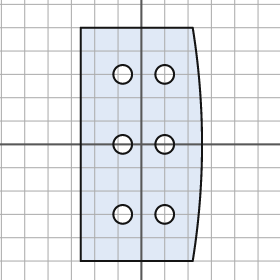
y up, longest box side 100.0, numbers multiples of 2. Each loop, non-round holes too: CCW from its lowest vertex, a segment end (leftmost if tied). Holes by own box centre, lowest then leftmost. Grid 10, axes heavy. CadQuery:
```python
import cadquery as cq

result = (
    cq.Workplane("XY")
    .moveTo(-26.0, -50.0)
    .lineTo(22.0, -50.0)
    .threePointArc((26.0, 0.0), (22.0, 50.0))
    .lineTo(-26.0, 50.0)
    .close()
    .moveTo(-8.0, -30.0)
    .circle(4.0)
    .moveTo(10.0, -30.0)
    .circle(4.0)
    .moveTo(-8.0, 0.0)
    .circle(4.0)
    .moveTo(10.0, 0.0)
    .circle(4.0)
    .moveTo(-8.0, 30.0)
    .circle(4.0)
    .moveTo(10.0, 30.0)
    .circle(4.0)
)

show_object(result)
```